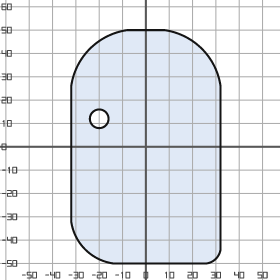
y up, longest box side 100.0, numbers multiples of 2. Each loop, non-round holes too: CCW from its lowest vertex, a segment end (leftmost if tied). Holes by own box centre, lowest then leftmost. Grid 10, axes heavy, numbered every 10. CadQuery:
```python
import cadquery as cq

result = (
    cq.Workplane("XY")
    .moveTo(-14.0, -50.0)
    .lineTo(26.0, -50.0)
    .threePointArc((30.0, -48.0), (32.0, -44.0))
    .lineTo(32.0, 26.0)
    .threePointArc((24.0, 42.0), (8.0, 50.0))
    .lineTo(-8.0, 50.0)
    .threePointArc((-24.0, 42.0), (-32.0, 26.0))
    .lineTo(-32.0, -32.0)
    .threePointArc((-26.0, -44.0), (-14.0, -50.0))
    .close()
    .moveTo(-20.0, 12.0)
    .circle(4.0)
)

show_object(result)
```